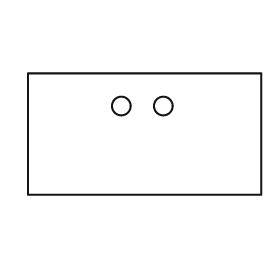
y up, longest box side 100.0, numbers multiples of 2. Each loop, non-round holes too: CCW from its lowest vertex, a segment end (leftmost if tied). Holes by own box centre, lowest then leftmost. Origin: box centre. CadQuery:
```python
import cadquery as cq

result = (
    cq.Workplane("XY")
    .moveTo(-50.0, -26.0)
    .lineTo(50.0, -26.0)
    .lineTo(50.0, 26.0)
    .lineTo(-50.0, 26.0)
    .close()
    .moveTo(-10.0, 12.0)
    .circle(4.0)
    .moveTo(8.0, 12.0)
    .circle(4.0)
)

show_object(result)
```